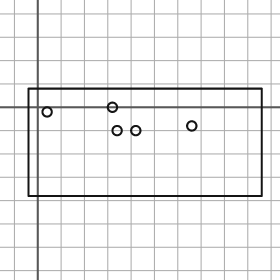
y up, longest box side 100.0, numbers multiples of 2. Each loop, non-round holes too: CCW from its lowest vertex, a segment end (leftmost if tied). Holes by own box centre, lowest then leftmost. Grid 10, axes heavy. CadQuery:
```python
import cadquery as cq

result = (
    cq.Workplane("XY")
    .moveTo(-4.0, -38.0)
    .lineTo(96.0, -38.0)
    .lineTo(96.0, 8.0)
    .lineTo(-4.0, 8.0)
    .close()
    .moveTo(34.0, -10.0)
    .circle(2.0)
    .moveTo(42.0, -10.0)
    .circle(2.0)
    .moveTo(66.0, -8.0)
    .circle(2.0)
    .moveTo(4.0, -2.0)
    .circle(2.0)
    .moveTo(32.0, 0.0)
    .circle(2.0)
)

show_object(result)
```